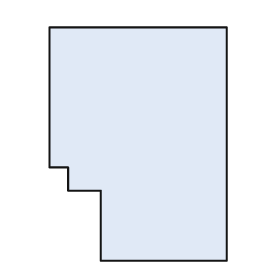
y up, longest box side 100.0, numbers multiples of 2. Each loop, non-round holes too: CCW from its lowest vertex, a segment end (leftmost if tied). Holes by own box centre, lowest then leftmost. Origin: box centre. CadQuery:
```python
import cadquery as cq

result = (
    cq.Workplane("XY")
    .moveTo(-16.0, -50.0)
    .lineTo(38.0, -50.0)
    .lineTo(38.0, 50.0)
    .lineTo(-38.0, 50.0)
    .lineTo(-38.0, -10.0)
    .lineTo(-30.0, -10.0)
    .lineTo(-30.0, -20.0)
    .lineTo(-16.0, -20.0)
    .close()
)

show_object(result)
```